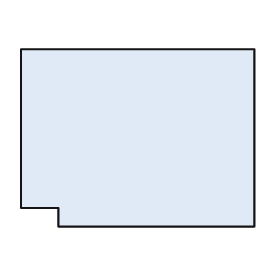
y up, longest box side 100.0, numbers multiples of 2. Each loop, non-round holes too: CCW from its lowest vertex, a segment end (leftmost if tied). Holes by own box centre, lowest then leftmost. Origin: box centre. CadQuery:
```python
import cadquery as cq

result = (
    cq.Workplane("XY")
    .moveTo(-34.0, -38.0)
    .lineTo(50.0, -38.0)
    .lineTo(50.0, 38.0)
    .lineTo(-50.0, 38.0)
    .lineTo(-50.0, -30.0)
    .lineTo(-34.0, -30.0)
    .close()
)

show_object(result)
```